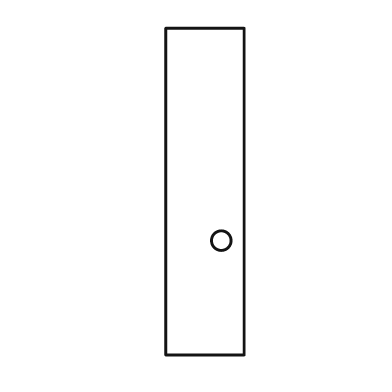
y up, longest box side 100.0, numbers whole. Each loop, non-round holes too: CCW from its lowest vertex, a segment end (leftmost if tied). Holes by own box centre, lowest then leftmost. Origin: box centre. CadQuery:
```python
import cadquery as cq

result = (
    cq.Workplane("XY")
    .moveTo(-12.0, -50.0)
    .lineTo(12.0, -50.0)
    .lineTo(12.0, 50.0)
    .lineTo(-12.0, 50.0)
    .close()
    .moveTo(5.0, -15.0)
    .circle(3.0)
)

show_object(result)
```